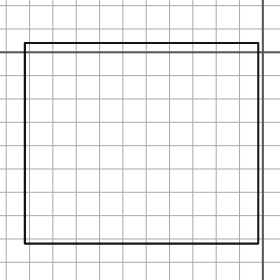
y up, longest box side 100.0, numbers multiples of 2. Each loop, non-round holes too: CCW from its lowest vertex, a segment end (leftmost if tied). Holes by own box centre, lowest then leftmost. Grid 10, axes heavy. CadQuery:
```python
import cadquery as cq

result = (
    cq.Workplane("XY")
    .moveTo(-102.0, -82.0)
    .lineTo(-2.0, -82.0)
    .lineTo(-2.0, 4.0)
    .lineTo(-102.0, 4.0)
    .close()
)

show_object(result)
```